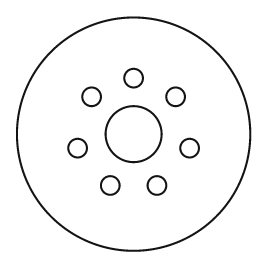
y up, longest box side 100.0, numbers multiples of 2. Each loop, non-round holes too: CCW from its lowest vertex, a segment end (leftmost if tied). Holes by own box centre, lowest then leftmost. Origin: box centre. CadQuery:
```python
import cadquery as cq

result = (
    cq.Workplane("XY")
    .moveTo(0.0, 0.0)
    .circle(50.0)
    .moveTo(-10.0, -22.0)
    .circle(4.0)
    .moveTo(10.0, -22.0)
    .circle(4.0)
    .moveTo(-24.0, -6.0)
    .circle(4.0)
    .moveTo(24.0, -6.0)
    .circle(4.0)
    .moveTo(0.0, 0.0)
    .circle(12.0)
    .moveTo(-18.0, 16.0)
    .circle(4.0)
    .moveTo(18.0, 16.0)
    .circle(4.0)
    .moveTo(0.0, 24.0)
    .circle(4.0)
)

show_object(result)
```